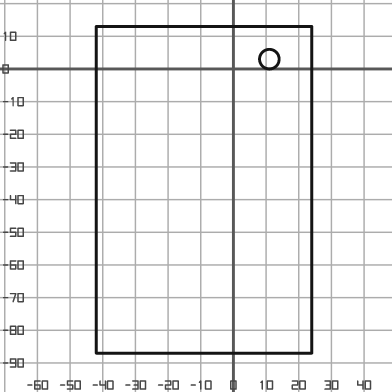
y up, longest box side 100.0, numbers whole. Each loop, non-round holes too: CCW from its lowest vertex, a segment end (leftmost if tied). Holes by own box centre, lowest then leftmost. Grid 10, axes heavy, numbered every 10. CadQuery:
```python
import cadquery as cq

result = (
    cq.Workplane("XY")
    .moveTo(-42.0, -87.0)
    .lineTo(24.0, -87.0)
    .lineTo(24.0, 13.0)
    .lineTo(-42.0, 13.0)
    .close()
    .moveTo(11.0, 3.0)
    .circle(3.0)
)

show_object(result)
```